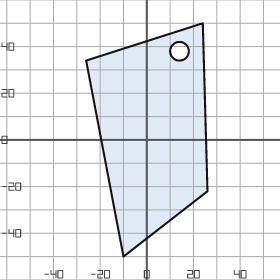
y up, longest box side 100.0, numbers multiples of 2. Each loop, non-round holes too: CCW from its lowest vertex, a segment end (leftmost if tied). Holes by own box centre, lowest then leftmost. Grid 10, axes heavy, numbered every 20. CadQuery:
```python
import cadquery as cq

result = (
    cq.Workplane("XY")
    .moveTo(-10.0, -50.0)
    .lineTo(26.0, -22.0)
    .lineTo(24.0, 50.0)
    .lineTo(-26.0, 34.0)
    .close()
    .moveTo(14.0, 38.0)
    .circle(4.0)
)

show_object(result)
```